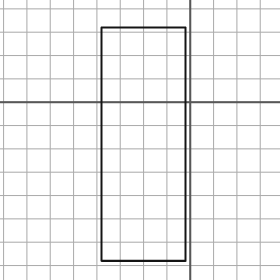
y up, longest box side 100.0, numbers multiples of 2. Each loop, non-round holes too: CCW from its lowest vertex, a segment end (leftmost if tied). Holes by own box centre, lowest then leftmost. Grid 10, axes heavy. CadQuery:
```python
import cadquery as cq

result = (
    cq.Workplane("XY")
    .moveTo(-38.0, -68.0)
    .lineTo(-2.0, -68.0)
    .lineTo(-2.0, 32.0)
    .lineTo(-38.0, 32.0)
    .close()
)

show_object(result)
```